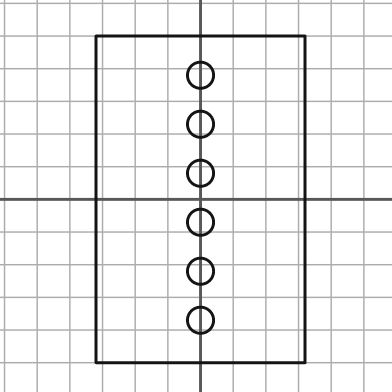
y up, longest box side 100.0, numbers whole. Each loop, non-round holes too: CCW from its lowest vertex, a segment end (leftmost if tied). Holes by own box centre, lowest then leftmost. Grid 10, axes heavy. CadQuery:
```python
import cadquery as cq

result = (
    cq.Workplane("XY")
    .moveTo(-32.0, -50.0)
    .lineTo(32.0, -50.0)
    .lineTo(32.0, 50.0)
    .lineTo(-32.0, 50.0)
    .close()
    .moveTo(0.0, -37.0)
    .circle(4.0)
    .moveTo(0.0, -22.0)
    .circle(4.0)
    .moveTo(0.0, -7.0)
    .circle(4.0)
    .moveTo(0.0, 8.0)
    .circle(4.0)
    .moveTo(0.0, 23.0)
    .circle(4.0)
    .moveTo(0.0, 38.0)
    .circle(4.0)
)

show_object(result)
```